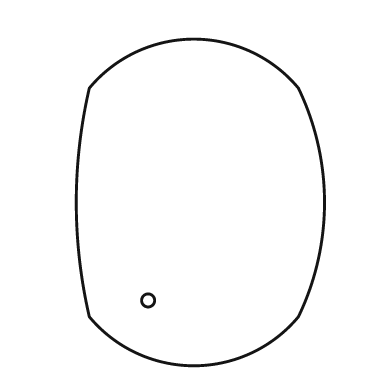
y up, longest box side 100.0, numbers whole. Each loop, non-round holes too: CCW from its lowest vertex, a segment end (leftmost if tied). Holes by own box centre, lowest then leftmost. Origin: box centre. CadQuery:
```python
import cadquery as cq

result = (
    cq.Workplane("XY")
    .moveTo(-34.0, -35.0)
    .threePointArc((-2.0, -50.0), (30.0, -35.0))
    .threePointArc((38.0, 0.0), (30.0, 35.0))
    .threePointArc((-2.0, 50.0), (-34.0, 35.0))
    .threePointArc((-38.0, 0.0), (-34.0, -35.0))
    .close()
    .moveTo(-16.0, -30.0)
    .circle(2.0)
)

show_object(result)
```